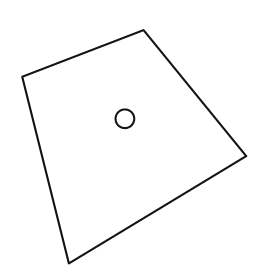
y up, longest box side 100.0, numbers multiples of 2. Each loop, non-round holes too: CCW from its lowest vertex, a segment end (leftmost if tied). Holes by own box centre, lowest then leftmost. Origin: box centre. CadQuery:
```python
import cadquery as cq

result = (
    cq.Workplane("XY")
    .moveTo(-28.0, -50.0)
    .lineTo(48.0, -4.0)
    .lineTo(4.0, 50.0)
    .lineTo(-48.0, 30.0)
    .close()
    .moveTo(-4.0, 12.0)
    .circle(4.0)
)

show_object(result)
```